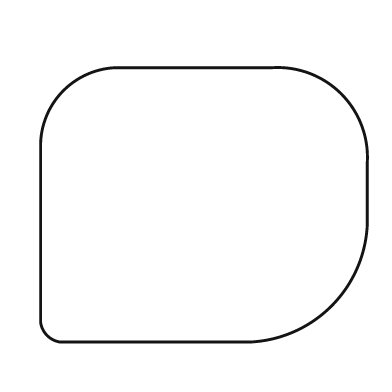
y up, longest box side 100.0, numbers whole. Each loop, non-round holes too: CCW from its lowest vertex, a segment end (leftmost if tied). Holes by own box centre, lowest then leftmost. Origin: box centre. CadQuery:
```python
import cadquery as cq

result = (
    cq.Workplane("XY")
    .moveTo(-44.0, -42.0)
    .lineTo(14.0, -42.0)
    .threePointArc((39.0, -31.0), (50.0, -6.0))
    .lineTo(50.0, 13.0)
    .threePointArc((42.0, 34.0), (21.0, 42.0))
    .lineTo(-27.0, 42.0)
    .threePointArc((-43.0, 35.0), (-50.0, 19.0))
    .lineTo(-50.0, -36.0)
    .threePointArc((-48.0, -40.0), (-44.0, -42.0))
    .close()
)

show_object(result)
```